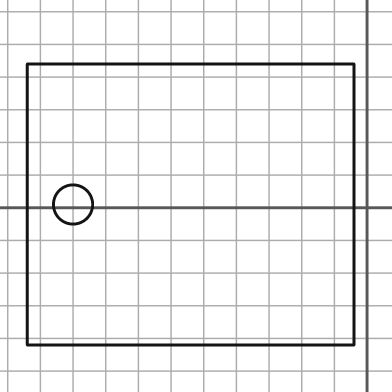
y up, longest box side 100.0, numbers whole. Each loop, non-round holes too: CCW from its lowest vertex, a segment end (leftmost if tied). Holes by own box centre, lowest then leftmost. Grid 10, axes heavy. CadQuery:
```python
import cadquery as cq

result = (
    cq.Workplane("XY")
    .moveTo(-104.0, -42.0)
    .lineTo(-4.0, -42.0)
    .lineTo(-4.0, 44.0)
    .lineTo(-104.0, 44.0)
    .close()
    .moveTo(-90.0, 1.0)
    .circle(6.0)
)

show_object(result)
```